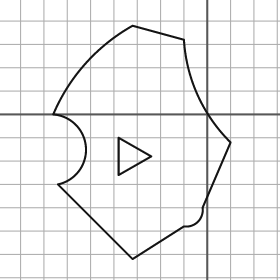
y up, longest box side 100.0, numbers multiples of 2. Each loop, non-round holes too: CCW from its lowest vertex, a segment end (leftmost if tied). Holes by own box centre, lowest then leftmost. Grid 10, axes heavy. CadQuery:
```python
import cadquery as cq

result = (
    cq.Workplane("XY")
    .moveTo(-32.0, -62.0)
    .lineTo(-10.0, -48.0)
    .threePointArc((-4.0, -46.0), (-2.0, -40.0))
    .lineTo(10.0, -12.0)
    .threePointArc((-4.0, 8.0), (-10.0, 32.0))
    .lineTo(-32.0, 38.0)
    .threePointArc((-52.0, 22.0), (-66.0, 0.0))
    .threePointArc((-52.0, -14.0), (-64.0, -30.0))
    .close()
    .moveTo(-38.0, -26.0)
    .lineTo(-24.0, -18.0)
    .lineTo(-38.0, -10.0)
    .close()
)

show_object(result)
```